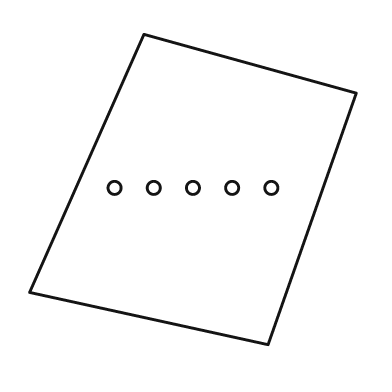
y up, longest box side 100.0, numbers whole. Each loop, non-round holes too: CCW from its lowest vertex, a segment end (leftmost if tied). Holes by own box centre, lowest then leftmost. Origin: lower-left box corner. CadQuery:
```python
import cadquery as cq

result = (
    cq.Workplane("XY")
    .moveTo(73.0, 0.0)
    .lineTo(100.0, 77.0)
    .lineTo(35.0, 95.0)
    .lineTo(0.0, 16.0)
    .close()
    .moveTo(26.0, 48.0)
    .circle(2.0)
    .moveTo(38.0, 48.0)
    .circle(2.0)
    .moveTo(50.0, 48.0)
    .circle(2.0)
    .moveTo(62.0, 48.0)
    .circle(2.0)
    .moveTo(74.0, 48.0)
    .circle(2.0)
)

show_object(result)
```